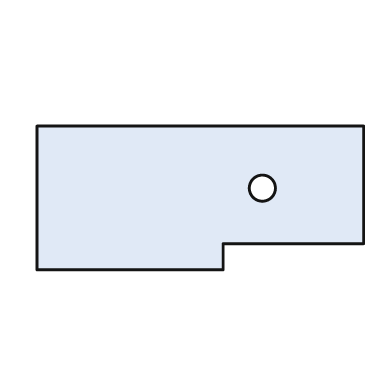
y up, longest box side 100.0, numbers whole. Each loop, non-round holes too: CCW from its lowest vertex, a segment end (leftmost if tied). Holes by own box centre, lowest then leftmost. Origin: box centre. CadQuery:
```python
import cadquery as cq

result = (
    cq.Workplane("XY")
    .moveTo(-50.0, -22.0)
    .lineTo(7.0, -22.0)
    .lineTo(7.0, -14.0)
    .lineTo(50.0, -14.0)
    .lineTo(50.0, 22.0)
    .lineTo(-50.0, 22.0)
    .close()
    .moveTo(19.0, 3.0)
    .circle(4.0)
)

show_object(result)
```